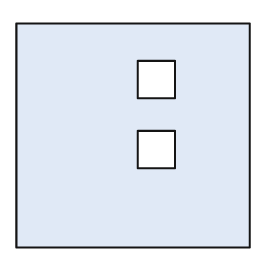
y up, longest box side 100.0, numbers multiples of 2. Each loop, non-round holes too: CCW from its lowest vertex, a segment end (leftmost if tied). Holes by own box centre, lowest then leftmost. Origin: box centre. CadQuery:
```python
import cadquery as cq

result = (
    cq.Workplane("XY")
    .moveTo(-50.0, -48.0)
    .lineTo(50.0, -48.0)
    .lineTo(50.0, 48.0)
    .lineTo(-50.0, 48.0)
    .close()
    .moveTo(2.0, -14.0)
    .lineTo(18.0, -14.0)
    .lineTo(18.0, 2.0)
    .lineTo(2.0, 2.0)
    .close()
    .moveTo(2.0, 16.0)
    .lineTo(18.0, 16.0)
    .lineTo(18.0, 32.0)
    .lineTo(2.0, 32.0)
    .close()
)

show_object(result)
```